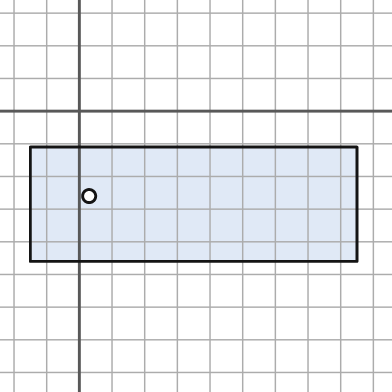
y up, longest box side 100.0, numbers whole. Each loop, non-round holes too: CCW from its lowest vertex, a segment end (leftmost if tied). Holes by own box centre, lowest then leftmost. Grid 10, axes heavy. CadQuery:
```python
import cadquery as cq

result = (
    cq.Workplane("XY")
    .moveTo(-15.0, -46.0)
    .lineTo(85.0, -46.0)
    .lineTo(85.0, -11.0)
    .lineTo(-15.0, -11.0)
    .close()
    .moveTo(3.0, -26.0)
    .circle(2.0)
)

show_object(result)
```